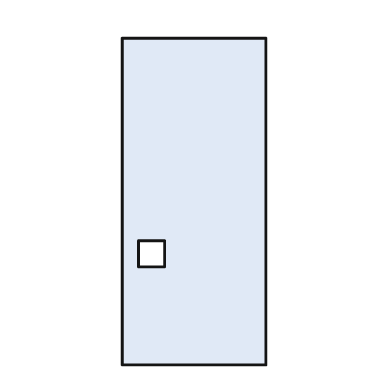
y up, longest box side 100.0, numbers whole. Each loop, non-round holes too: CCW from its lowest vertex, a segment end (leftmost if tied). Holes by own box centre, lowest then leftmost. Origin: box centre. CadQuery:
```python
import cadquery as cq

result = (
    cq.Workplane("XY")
    .moveTo(-22.0, -50.0)
    .lineTo(22.0, -50.0)
    .lineTo(22.0, 50.0)
    .lineTo(-22.0, 50.0)
    .close()
    .moveTo(-17.0, -20.0)
    .lineTo(-9.0, -20.0)
    .lineTo(-9.0, -12.0)
    .lineTo(-17.0, -12.0)
    .close()
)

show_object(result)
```